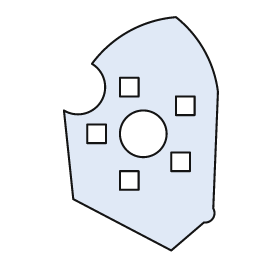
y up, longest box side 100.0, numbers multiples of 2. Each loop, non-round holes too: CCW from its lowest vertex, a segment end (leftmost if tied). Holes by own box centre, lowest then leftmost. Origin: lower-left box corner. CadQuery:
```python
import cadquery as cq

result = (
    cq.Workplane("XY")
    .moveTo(46.0, 0.0)
    .lineTo(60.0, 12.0)
    .threePointArc((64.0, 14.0), (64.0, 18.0))
    .lineTo(66.0, 68.0)
    .threePointArc((60.0, 86.0), (48.0, 100.0))
    .threePointArc((28.0, 94.0), (12.0, 80.0))
    .threePointArc((16.0, 64.0), (0.0, 60.0))
    .lineTo(4.0, 22.0)
    .close()
    .moveTo(24.0, 26.0)
    .lineTo(32.0, 26.0)
    .lineTo(32.0, 34.0)
    .lineTo(24.0, 34.0)
    .close()
    .moveTo(46.0, 34.0)
    .lineTo(54.0, 34.0)
    .lineTo(54.0, 42.0)
    .lineTo(46.0, 42.0)
    .close()
    .moveTo(10.0, 46.0)
    .lineTo(18.0, 46.0)
    .lineTo(18.0, 54.0)
    .lineTo(10.0, 54.0)
    .close()
    .moveTo(34.0, 50.0)
    .circle(10.0)
    .moveTo(48.0, 58.0)
    .lineTo(56.0, 58.0)
    .lineTo(56.0, 66.0)
    .lineTo(48.0, 66.0)
    .close()
    .moveTo(24.0, 66.0)
    .lineTo(32.0, 66.0)
    .lineTo(32.0, 74.0)
    .lineTo(24.0, 74.0)
    .close()
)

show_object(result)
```